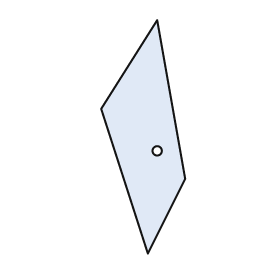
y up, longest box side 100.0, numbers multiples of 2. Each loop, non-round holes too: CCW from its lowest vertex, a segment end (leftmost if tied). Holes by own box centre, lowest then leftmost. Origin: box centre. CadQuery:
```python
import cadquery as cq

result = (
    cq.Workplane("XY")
    .moveTo(2.0, -50.0)
    .lineTo(18.0, -18.0)
    .lineTo(6.0, 50.0)
    .lineTo(-18.0, 12.0)
    .close()
    .moveTo(6.0, -6.0)
    .circle(2.0)
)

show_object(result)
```